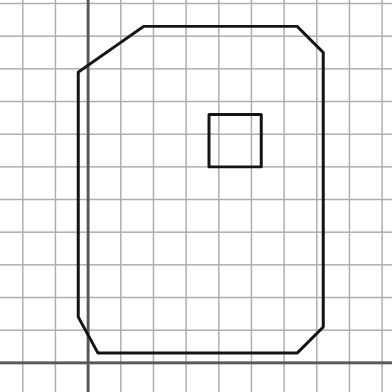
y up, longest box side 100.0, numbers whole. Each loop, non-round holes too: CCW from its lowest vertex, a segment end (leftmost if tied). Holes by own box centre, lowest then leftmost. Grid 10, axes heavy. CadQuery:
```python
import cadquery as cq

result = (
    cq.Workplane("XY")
    .moveTo(3.0, 3.0)
    .lineTo(64.0, 3.0)
    .lineTo(72.0, 11.0)
    .lineTo(72.0, 95.0)
    .lineTo(64.0, 103.0)
    .lineTo(17.0, 103.0)
    .lineTo(-3.0, 89.0)
    .lineTo(-3.0, 14.0)
    .close()
    .moveTo(37.0, 60.0)
    .lineTo(53.0, 60.0)
    .lineTo(53.0, 76.0)
    .lineTo(37.0, 76.0)
    .close()
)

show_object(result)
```